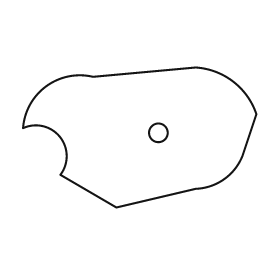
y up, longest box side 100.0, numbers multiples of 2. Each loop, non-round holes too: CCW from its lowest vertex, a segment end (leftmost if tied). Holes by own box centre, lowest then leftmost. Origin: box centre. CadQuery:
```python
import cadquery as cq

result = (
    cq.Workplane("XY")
    .moveTo(-10.0, -30.0)
    .lineTo(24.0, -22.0)
    .threePointArc((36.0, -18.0), (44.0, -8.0))
    .lineTo(50.0, 10.0)
    .threePointArc((40.0, 24.0), (24.0, 30.0))
    .lineTo(-20.0, 26.0)
    .threePointArc((-40.0, 22.0), (-50.0, 4.0))
    .threePointArc((-34.0, 0.0), (-34.0, -16.0))
    .close()
    .moveTo(8.0, 2.0)
    .circle(4.0)
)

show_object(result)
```